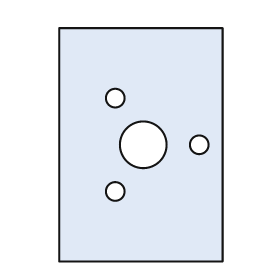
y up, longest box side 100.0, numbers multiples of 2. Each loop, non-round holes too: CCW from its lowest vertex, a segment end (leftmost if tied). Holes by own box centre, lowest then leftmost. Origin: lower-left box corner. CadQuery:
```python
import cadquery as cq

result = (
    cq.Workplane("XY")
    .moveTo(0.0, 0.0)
    .lineTo(70.0, 0.0)
    .lineTo(70.0, 100.0)
    .lineTo(0.0, 100.0)
    .close()
    .moveTo(24.0, 30.0)
    .circle(4.0)
    .moveTo(36.0, 50.0)
    .circle(10.0)
    .moveTo(60.0, 50.0)
    .circle(4.0)
    .moveTo(24.0, 70.0)
    .circle(4.0)
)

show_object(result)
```